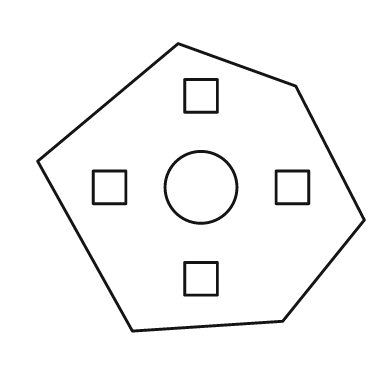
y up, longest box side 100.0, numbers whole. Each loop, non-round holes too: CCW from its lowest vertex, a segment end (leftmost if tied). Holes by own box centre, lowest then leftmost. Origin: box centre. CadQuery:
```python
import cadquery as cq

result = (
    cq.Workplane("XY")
    .moveTo(-21.0, -44.0)
    .lineTo(25.0, -41.0)
    .lineTo(50.0, -10.0)
    .lineTo(29.0, 31.0)
    .lineTo(-7.0, 44.0)
    .lineTo(-50.0, 8.0)
    .close()
    .moveTo(-5.0, -33.0)
    .lineTo(5.0, -33.0)
    .lineTo(5.0, -23.0)
    .lineTo(-5.0, -23.0)
    .close()
    .moveTo(-33.0, -5.0)
    .lineTo(-23.0, -5.0)
    .lineTo(-23.0, 5.0)
    .lineTo(-33.0, 5.0)
    .close()
    .moveTo(0.0, 0.0)
    .circle(11.0)
    .moveTo(23.0, -5.0)
    .lineTo(33.0, -5.0)
    .lineTo(33.0, 5.0)
    .lineTo(23.0, 5.0)
    .close()
    .moveTo(-5.0, 23.0)
    .lineTo(5.0, 23.0)
    .lineTo(5.0, 33.0)
    .lineTo(-5.0, 33.0)
    .close()
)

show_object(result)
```